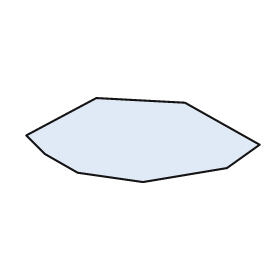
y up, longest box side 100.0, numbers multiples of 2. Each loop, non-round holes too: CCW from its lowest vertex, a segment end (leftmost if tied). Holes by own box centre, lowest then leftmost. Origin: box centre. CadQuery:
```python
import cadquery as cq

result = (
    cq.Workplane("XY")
    .moveTo(0.0, -18.0)
    .lineTo(36.0, -12.0)
    .lineTo(50.0, -2.0)
    .lineTo(18.0, 16.0)
    .lineTo(-20.0, 18.0)
    .lineTo(-50.0, 2.0)
    .lineTo(-42.0, -6.0)
    .lineTo(-28.0, -14.0)
    .close()
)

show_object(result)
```